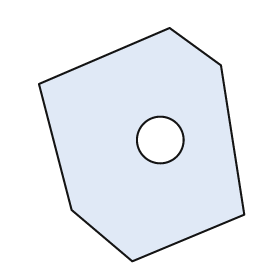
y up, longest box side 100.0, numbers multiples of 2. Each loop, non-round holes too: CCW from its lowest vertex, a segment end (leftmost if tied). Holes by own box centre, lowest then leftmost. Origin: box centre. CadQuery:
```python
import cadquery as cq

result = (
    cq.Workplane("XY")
    .moveTo(-4.0, -50.0)
    .lineTo(44.0, -30.0)
    .lineTo(34.0, 34.0)
    .lineTo(12.0, 50.0)
    .lineTo(-44.0, 26.0)
    .lineTo(-30.0, -28.0)
    .close()
    .moveTo(8.0, 2.0)
    .circle(10.0)
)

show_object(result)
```